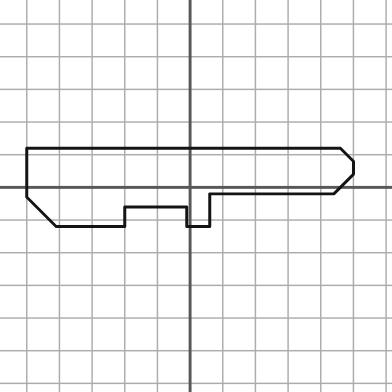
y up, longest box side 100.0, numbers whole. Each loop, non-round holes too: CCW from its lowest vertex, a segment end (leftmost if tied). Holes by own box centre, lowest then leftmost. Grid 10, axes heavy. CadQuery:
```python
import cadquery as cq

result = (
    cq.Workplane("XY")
    .moveTo(-41.0, -12.0)
    .lineTo(-20.0, -12.0)
    .lineTo(-20.0, -6.0)
    .lineTo(-1.0, -6.0)
    .lineTo(-1.0, -12.0)
    .lineTo(6.0, -12.0)
    .lineTo(6.0, -2.0)
    .lineTo(44.0, -2.0)
    .lineTo(50.0, 4.0)
    .lineTo(50.0, 8.0)
    .lineTo(46.0, 12.0)
    .lineTo(-50.0, 12.0)
    .lineTo(-50.0, -3.0)
    .close()
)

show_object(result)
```